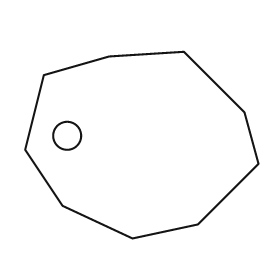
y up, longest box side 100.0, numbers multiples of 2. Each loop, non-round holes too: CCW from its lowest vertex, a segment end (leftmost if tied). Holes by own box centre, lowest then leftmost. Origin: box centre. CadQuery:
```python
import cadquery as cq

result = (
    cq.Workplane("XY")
    .moveTo(-4.0, -40.0)
    .lineTo(24.0, -34.0)
    .lineTo(50.0, -8.0)
    .lineTo(44.0, 14.0)
    .lineTo(18.0, 40.0)
    .lineTo(-14.0, 38.0)
    .lineTo(-42.0, 30.0)
    .lineTo(-50.0, -2.0)
    .lineTo(-34.0, -26.0)
    .close()
    .moveTo(-32.0, 4.0)
    .circle(6.0)
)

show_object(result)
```